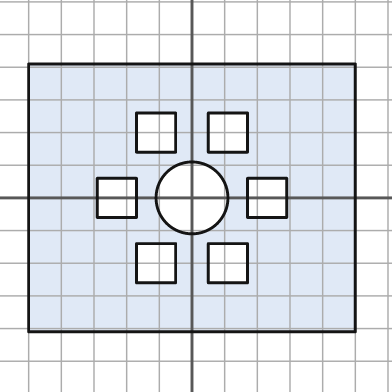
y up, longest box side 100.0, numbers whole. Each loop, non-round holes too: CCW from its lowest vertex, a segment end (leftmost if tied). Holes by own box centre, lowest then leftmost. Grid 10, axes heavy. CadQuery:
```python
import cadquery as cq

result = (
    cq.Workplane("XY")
    .moveTo(-50.0, -41.0)
    .lineTo(50.0, -41.0)
    .lineTo(50.0, 41.0)
    .lineTo(-50.0, 41.0)
    .close()
    .moveTo(-17.0, -26.0)
    .lineTo(-5.0, -26.0)
    .lineTo(-5.0, -14.0)
    .lineTo(-17.0, -14.0)
    .close()
    .moveTo(5.0, -26.0)
    .lineTo(17.0, -26.0)
    .lineTo(17.0, -14.0)
    .lineTo(5.0, -14.0)
    .close()
    .moveTo(-29.0, -6.0)
    .lineTo(-17.0, -6.0)
    .lineTo(-17.0, 6.0)
    .lineTo(-29.0, 6.0)
    .close()
    .moveTo(0.0, 0.0)
    .circle(11.0)
    .moveTo(17.0, -6.0)
    .lineTo(29.0, -6.0)
    .lineTo(29.0, 6.0)
    .lineTo(17.0, 6.0)
    .close()
    .moveTo(-17.0, 14.0)
    .lineTo(-5.0, 14.0)
    .lineTo(-5.0, 26.0)
    .lineTo(-17.0, 26.0)
    .close()
    .moveTo(5.0, 14.0)
    .lineTo(17.0, 14.0)
    .lineTo(17.0, 26.0)
    .lineTo(5.0, 26.0)
    .close()
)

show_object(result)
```